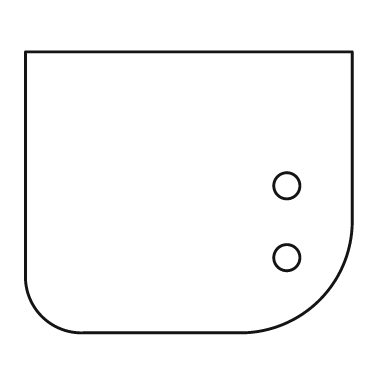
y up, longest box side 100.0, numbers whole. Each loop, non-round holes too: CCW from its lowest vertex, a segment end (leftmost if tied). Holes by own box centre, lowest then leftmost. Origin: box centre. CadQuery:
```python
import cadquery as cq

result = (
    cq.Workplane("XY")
    .moveTo(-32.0, -43.0)
    .lineTo(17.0, -43.0)
    .threePointArc((40.0, -33.0), (50.0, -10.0))
    .lineTo(50.0, 43.0)
    .lineTo(-50.0, 43.0)
    .lineTo(-50.0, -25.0)
    .threePointArc((-45.0, -38.0), (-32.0, -43.0))
    .close()
    .moveTo(30.0, -20.0)
    .circle(4.0)
    .moveTo(30.0, 2.0)
    .circle(4.0)
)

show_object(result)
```